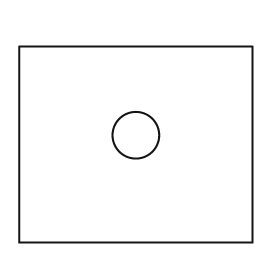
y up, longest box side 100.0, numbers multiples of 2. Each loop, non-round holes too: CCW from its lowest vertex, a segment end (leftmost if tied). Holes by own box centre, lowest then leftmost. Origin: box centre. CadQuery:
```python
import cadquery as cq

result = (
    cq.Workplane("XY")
    .moveTo(-50.0, -42.0)
    .lineTo(50.0, -42.0)
    .lineTo(50.0, 42.0)
    .lineTo(-50.0, 42.0)
    .close()
    .moveTo(0.0, 4.0)
    .circle(10.0)
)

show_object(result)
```